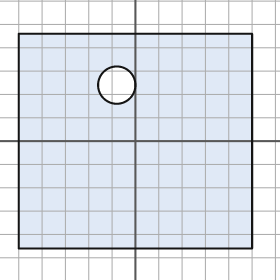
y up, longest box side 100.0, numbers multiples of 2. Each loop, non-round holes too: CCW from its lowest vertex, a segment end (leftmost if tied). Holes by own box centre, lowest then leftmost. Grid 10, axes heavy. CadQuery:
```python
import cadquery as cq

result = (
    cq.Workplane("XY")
    .moveTo(-50.0, -46.0)
    .lineTo(50.0, -46.0)
    .lineTo(50.0, 46.0)
    .lineTo(-50.0, 46.0)
    .close()
    .moveTo(-8.0, 24.0)
    .circle(8.0)
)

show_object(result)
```